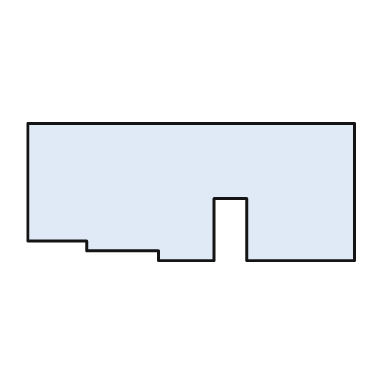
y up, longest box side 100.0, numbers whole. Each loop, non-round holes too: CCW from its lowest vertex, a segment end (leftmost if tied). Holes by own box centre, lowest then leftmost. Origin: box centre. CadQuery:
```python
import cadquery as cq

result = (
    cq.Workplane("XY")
    .moveTo(-10.0, -21.0)
    .lineTo(7.0, -21.0)
    .lineTo(7.0, -2.0)
    .lineTo(17.0, -2.0)
    .lineTo(17.0, -21.0)
    .lineTo(50.0, -21.0)
    .lineTo(50.0, 21.0)
    .lineTo(-50.0, 21.0)
    .lineTo(-50.0, -15.0)
    .lineTo(-32.0, -15.0)
    .lineTo(-32.0, -18.0)
    .lineTo(-10.0, -18.0)
    .close()
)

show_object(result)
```